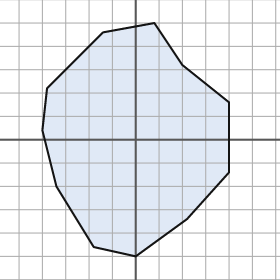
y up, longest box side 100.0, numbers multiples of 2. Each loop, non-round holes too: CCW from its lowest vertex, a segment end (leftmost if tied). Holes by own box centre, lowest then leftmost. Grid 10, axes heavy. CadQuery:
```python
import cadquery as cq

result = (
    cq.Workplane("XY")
    .moveTo(0.0, -50.0)
    .lineTo(22.0, -34.0)
    .lineTo(40.0, -14.0)
    .lineTo(40.0, 16.0)
    .lineTo(20.0, 32.0)
    .lineTo(8.0, 50.0)
    .lineTo(-14.0, 46.0)
    .lineTo(-38.0, 22.0)
    .lineTo(-40.0, 4.0)
    .lineTo(-34.0, -20.0)
    .lineTo(-18.0, -46.0)
    .close()
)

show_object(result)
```